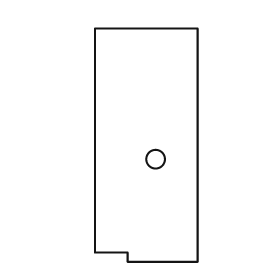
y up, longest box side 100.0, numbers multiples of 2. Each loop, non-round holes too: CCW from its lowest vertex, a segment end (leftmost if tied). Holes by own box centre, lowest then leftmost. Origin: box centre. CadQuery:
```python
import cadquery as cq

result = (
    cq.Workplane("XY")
    .moveTo(-8.0, -50.0)
    .lineTo(22.0, -50.0)
    .lineTo(22.0, 50.0)
    .lineTo(-22.0, 50.0)
    .lineTo(-22.0, -46.0)
    .lineTo(-8.0, -46.0)
    .close()
    .moveTo(4.0, -6.0)
    .circle(4.0)
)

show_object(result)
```